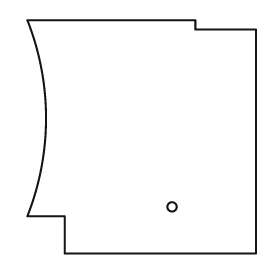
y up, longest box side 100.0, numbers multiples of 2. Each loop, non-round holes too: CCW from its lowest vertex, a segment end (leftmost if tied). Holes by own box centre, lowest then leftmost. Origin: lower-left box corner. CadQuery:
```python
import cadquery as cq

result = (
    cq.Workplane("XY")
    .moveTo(16.0, 0.0)
    .lineTo(98.0, 0.0)
    .lineTo(98.0, 96.0)
    .lineTo(72.0, 96.0)
    .lineTo(72.0, 100.0)
    .lineTo(0.0, 100.0)
    .threePointArc((8.0, 58.0), (0.0, 16.0))
    .lineTo(16.0, 16.0)
    .close()
    .moveTo(62.0, 20.0)
    .circle(2.0)
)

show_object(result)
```